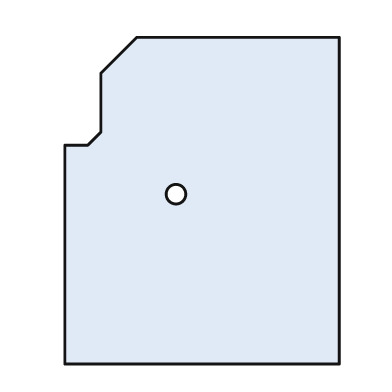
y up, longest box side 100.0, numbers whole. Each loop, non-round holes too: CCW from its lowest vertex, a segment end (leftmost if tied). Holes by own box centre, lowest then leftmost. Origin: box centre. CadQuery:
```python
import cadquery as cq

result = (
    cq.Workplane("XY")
    .moveTo(-42.0, -50.0)
    .lineTo(42.0, -50.0)
    .lineTo(42.0, 50.0)
    .lineTo(-20.0, 50.0)
    .lineTo(-31.0, 39.0)
    .lineTo(-31.0, 21.0)
    .lineTo(-35.0, 17.0)
    .lineTo(-42.0, 17.0)
    .close()
    .moveTo(-8.0, 2.0)
    .circle(3.0)
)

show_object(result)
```